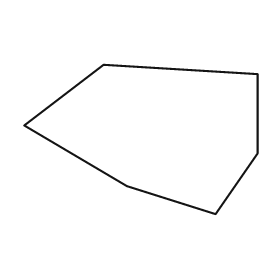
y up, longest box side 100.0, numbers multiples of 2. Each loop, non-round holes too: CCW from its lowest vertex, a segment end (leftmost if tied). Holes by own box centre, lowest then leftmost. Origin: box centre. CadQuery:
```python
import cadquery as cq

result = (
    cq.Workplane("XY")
    .moveTo(32.0, -32.0)
    .lineTo(50.0, -6.0)
    .lineTo(50.0, 28.0)
    .lineTo(-16.0, 32.0)
    .lineTo(-50.0, 6.0)
    .lineTo(-6.0, -20.0)
    .close()
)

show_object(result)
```